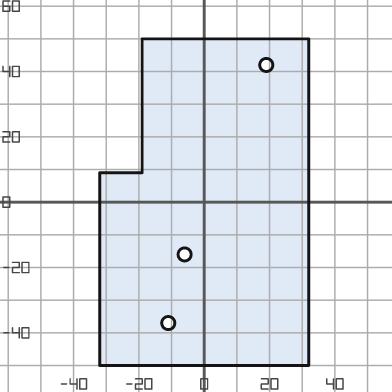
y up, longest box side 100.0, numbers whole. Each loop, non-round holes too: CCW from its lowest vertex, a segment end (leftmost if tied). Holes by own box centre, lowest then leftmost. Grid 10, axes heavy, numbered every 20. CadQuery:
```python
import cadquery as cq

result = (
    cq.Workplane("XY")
    .moveTo(-32.0, -50.0)
    .lineTo(32.0, -50.0)
    .lineTo(32.0, 50.0)
    .lineTo(-19.0, 50.0)
    .lineTo(-19.0, 9.0)
    .lineTo(-32.0, 9.0)
    .close()
    .moveTo(-11.0, -37.0)
    .circle(2.0)
    .moveTo(-6.0, -16.0)
    .circle(2.0)
    .moveTo(19.0, 42.0)
    .circle(2.0)
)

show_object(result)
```